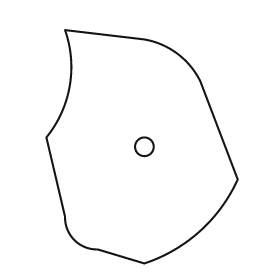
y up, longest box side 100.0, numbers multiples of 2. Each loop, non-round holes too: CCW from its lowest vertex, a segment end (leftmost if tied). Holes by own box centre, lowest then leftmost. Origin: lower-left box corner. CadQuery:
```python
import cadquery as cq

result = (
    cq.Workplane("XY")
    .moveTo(42.0, 0.0)
    .threePointArc((66.0, 14.0), (82.0, 36.0))
    .lineTo(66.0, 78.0)
    .threePointArc((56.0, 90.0), (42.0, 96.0))
    .lineTo(8.0, 100.0)
    .threePointArc((10.0, 76.0), (0.0, 54.0))
    .lineTo(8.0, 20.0)
    .threePointArc((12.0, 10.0), (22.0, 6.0))
    .close()
    .moveTo(42.0, 50.0)
    .circle(4.0)
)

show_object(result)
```